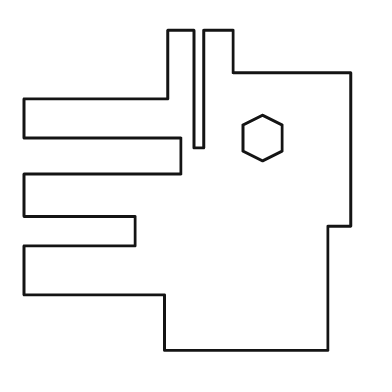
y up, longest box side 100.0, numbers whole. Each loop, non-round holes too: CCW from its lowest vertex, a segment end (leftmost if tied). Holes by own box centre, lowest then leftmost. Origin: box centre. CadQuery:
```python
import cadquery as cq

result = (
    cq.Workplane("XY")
    .moveTo(-7.0, -49.0)
    .lineTo(43.0, -49.0)
    .lineTo(43.0, -11.0)
    .lineTo(50.0, -11.0)
    .lineTo(50.0, 36.0)
    .lineTo(14.0, 36.0)
    .lineTo(14.0, 49.0)
    .lineTo(5.0, 49.0)
    .lineTo(5.0, 13.0)
    .lineTo(2.0, 13.0)
    .lineTo(2.0, 49.0)
    .lineTo(-6.0, 49.0)
    .lineTo(-6.0, 28.0)
    .lineTo(-50.0, 28.0)
    .lineTo(-50.0, 16.0)
    .lineTo(-2.0, 16.0)
    .lineTo(-2.0, 5.0)
    .lineTo(-50.0, 5.0)
    .lineTo(-50.0, -8.0)
    .lineTo(-16.0, -8.0)
    .lineTo(-16.0, -17.0)
    .lineTo(-50.0, -17.0)
    .lineTo(-50.0, -32.0)
    .lineTo(-7.0, -32.0)
    .close()
    .moveTo(23.0, 9.0)
    .lineTo(29.0, 12.0)
    .lineTo(29.0, 20.0)
    .lineTo(23.0, 23.0)
    .lineTo(17.0, 20.0)
    .lineTo(17.0, 12.0)
    .close()
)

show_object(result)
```